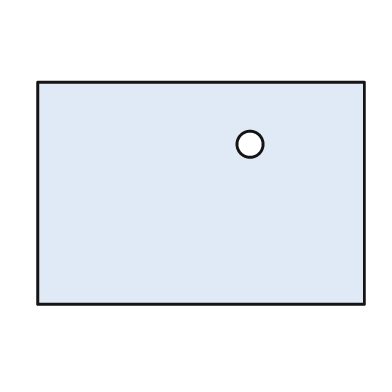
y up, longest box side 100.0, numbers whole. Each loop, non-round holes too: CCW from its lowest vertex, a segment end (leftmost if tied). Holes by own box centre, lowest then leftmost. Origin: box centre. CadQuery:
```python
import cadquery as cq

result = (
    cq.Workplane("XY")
    .moveTo(-50.0, -34.0)
    .lineTo(50.0, -34.0)
    .lineTo(50.0, 34.0)
    .lineTo(-50.0, 34.0)
    .close()
    .moveTo(15.0, 15.0)
    .circle(4.0)
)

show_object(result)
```